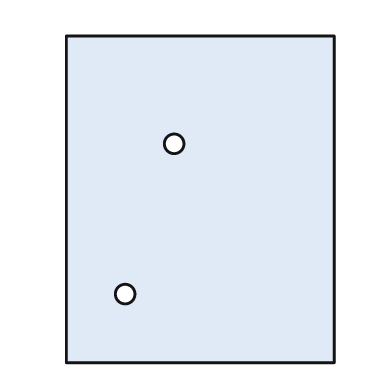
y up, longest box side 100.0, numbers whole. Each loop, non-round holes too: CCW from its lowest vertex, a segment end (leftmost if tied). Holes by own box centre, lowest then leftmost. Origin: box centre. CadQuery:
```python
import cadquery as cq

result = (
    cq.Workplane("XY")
    .moveTo(-41.0, -50.0)
    .lineTo(41.0, -50.0)
    .lineTo(41.0, 50.0)
    .lineTo(-41.0, 50.0)
    .close()
    .moveTo(-23.0, -29.0)
    .circle(3.0)
    .moveTo(-8.0, 17.0)
    .circle(3.0)
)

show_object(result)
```